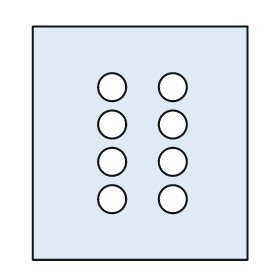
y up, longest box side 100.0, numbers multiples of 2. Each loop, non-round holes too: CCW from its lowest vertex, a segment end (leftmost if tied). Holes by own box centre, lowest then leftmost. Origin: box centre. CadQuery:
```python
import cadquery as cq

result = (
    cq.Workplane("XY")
    .moveTo(-46.0, -50.0)
    .lineTo(46.0, -50.0)
    .lineTo(46.0, 50.0)
    .lineTo(-46.0, 50.0)
    .close()
    .moveTo(-12.0, -24.0)
    .circle(6.0)
    .moveTo(14.0, -24.0)
    .circle(6.0)
    .moveTo(-12.0, -8.0)
    .circle(6.0)
    .moveTo(14.0, -8.0)
    .circle(6.0)
    .moveTo(-12.0, 8.0)
    .circle(6.0)
    .moveTo(14.0, 8.0)
    .circle(6.0)
    .moveTo(-12.0, 24.0)
    .circle(6.0)
    .moveTo(14.0, 24.0)
    .circle(6.0)
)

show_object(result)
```